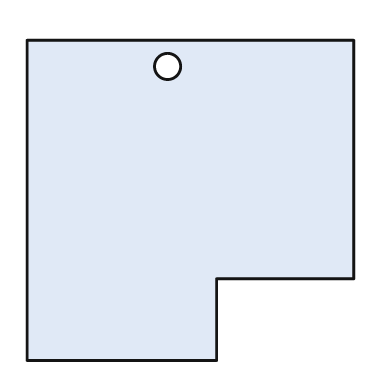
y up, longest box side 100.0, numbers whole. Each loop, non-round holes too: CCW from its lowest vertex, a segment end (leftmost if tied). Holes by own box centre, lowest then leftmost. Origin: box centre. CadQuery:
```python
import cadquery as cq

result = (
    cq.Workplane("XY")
    .moveTo(-50.0, -49.0)
    .lineTo(8.0, -49.0)
    .lineTo(8.0, -24.0)
    .lineTo(50.0, -24.0)
    .lineTo(50.0, 49.0)
    .lineTo(-50.0, 49.0)
    .close()
    .moveTo(-7.0, 41.0)
    .circle(4.0)
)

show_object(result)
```